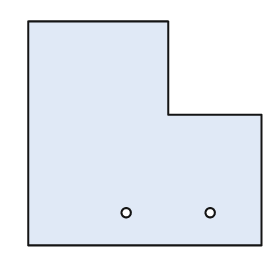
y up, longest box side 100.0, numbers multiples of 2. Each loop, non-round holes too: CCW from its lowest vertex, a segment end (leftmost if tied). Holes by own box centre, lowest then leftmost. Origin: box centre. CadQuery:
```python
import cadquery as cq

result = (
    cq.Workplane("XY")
    .moveTo(-50.0, -48.0)
    .lineTo(50.0, -48.0)
    .lineTo(50.0, 8.0)
    .lineTo(10.0, 8.0)
    .lineTo(10.0, 48.0)
    .lineTo(-50.0, 48.0)
    .close()
    .moveTo(-8.0, -34.0)
    .circle(2.0)
    .moveTo(28.0, -34.0)
    .circle(2.0)
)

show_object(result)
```